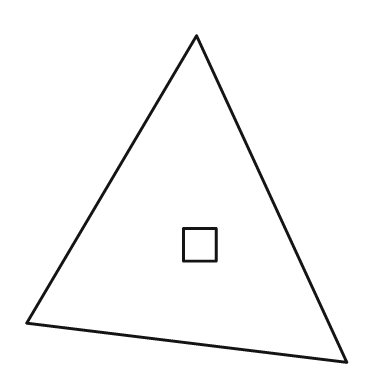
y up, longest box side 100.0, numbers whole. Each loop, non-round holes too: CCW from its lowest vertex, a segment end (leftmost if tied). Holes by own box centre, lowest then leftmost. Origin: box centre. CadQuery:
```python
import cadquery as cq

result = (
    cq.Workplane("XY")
    .moveTo(49.0, -50.0)
    .lineTo(3.0, 50.0)
    .lineTo(-49.0, -38.0)
    .close()
    .moveTo(-1.0, -19.0)
    .lineTo(9.0, -19.0)
    .lineTo(9.0, -9.0)
    .lineTo(-1.0, -9.0)
    .close()
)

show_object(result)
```